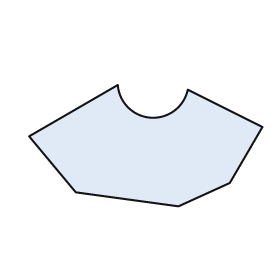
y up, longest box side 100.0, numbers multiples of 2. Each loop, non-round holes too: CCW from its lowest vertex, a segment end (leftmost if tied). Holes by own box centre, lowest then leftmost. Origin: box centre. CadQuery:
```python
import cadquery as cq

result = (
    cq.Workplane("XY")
    .moveTo(14.0, -26.0)
    .lineTo(36.0, -16.0)
    .lineTo(50.0, 8.0)
    .lineTo(18.0, 24.0)
    .threePointArc((2.0, 12.0), (-12.0, 26.0))
    .lineTo(-50.0, 4.0)
    .lineTo(-30.0, -20.0)
    .close()
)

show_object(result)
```